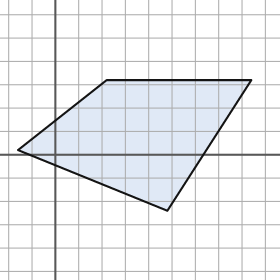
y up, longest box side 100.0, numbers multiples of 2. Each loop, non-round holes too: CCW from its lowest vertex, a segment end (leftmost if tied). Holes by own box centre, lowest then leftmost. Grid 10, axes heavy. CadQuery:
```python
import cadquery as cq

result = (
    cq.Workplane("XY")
    .moveTo(48.0, -24.0)
    .lineTo(84.0, 32.0)
    .lineTo(22.0, 32.0)
    .lineTo(-16.0, 2.0)
    .close()
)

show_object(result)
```